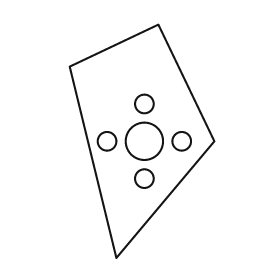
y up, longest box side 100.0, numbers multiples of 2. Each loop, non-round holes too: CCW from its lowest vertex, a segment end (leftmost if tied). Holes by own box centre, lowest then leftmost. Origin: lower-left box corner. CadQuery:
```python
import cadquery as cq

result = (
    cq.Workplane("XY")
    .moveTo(20.0, 0.0)
    .lineTo(62.0, 50.0)
    .lineTo(38.0, 100.0)
    .lineTo(0.0, 82.0)
    .close()
    .moveTo(32.0, 34.0)
    .circle(4.0)
    .moveTo(16.0, 50.0)
    .circle(4.0)
    .moveTo(32.0, 50.0)
    .circle(8.0)
    .moveTo(48.0, 50.0)
    .circle(4.0)
    .moveTo(32.0, 66.0)
    .circle(4.0)
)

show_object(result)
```